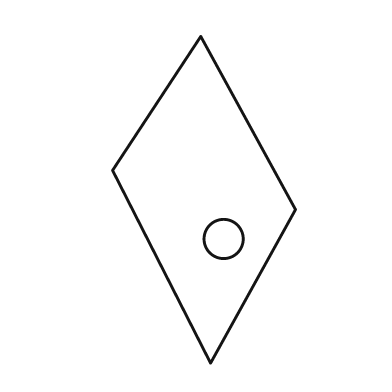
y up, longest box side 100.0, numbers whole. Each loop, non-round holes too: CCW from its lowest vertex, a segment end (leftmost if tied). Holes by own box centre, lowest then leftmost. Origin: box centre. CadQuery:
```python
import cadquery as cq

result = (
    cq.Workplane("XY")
    .moveTo(2.0, -50.0)
    .lineTo(28.0, -3.0)
    .lineTo(-1.0, 50.0)
    .lineTo(-28.0, 9.0)
    .close()
    .moveTo(6.0, -12.0)
    .circle(6.0)
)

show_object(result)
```